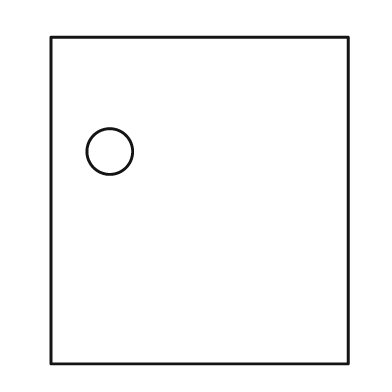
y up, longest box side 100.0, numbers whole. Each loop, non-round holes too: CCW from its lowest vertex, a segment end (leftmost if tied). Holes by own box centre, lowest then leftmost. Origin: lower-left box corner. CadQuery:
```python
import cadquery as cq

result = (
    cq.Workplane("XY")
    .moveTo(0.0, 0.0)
    .lineTo(91.0, 0.0)
    .lineTo(91.0, 100.0)
    .lineTo(0.0, 100.0)
    .close()
    .moveTo(18.0, 65.0)
    .circle(7.0)
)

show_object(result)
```